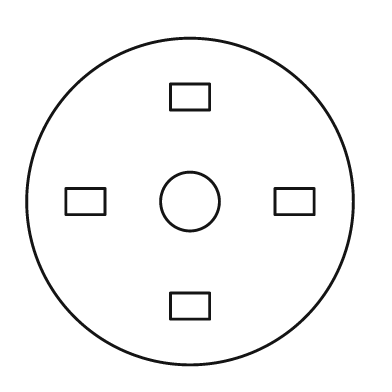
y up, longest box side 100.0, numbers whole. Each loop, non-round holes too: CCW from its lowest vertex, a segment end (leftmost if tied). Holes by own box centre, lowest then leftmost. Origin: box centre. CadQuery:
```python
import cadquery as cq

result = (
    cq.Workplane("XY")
    .moveTo(0.0, 0.0)
    .circle(50.0)
    .moveTo(-6.0, -36.0)
    .lineTo(6.0, -36.0)
    .lineTo(6.0, -28.0)
    .lineTo(-6.0, -28.0)
    .close()
    .moveTo(-38.0, -4.0)
    .lineTo(-26.0, -4.0)
    .lineTo(-26.0, 4.0)
    .lineTo(-38.0, 4.0)
    .close()
    .moveTo(0.0, 0.0)
    .circle(9.0)
    .moveTo(26.0, -4.0)
    .lineTo(38.0, -4.0)
    .lineTo(38.0, 4.0)
    .lineTo(26.0, 4.0)
    .close()
    .moveTo(-6.0, 28.0)
    .lineTo(6.0, 28.0)
    .lineTo(6.0, 36.0)
    .lineTo(-6.0, 36.0)
    .close()
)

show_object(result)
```